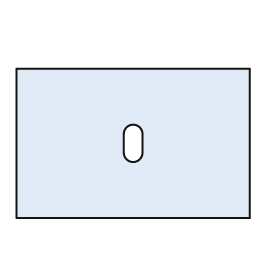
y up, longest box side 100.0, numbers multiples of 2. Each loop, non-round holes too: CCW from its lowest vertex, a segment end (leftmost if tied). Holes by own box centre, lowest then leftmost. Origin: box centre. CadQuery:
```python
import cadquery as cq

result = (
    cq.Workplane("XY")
    .moveTo(-50.0, -32.0)
    .lineTo(50.0, -32.0)
    .lineTo(50.0, 32.0)
    .lineTo(-50.0, 32.0)
    .close()
    .moveTo(-4.0, -4.0)
    .threePointArc((0.0, -8.0), (4.0, -4.0))
    .lineTo(4.0, 4.0)
    .threePointArc((0.0, 8.0), (-4.0, 4.0))
    .close()
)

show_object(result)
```